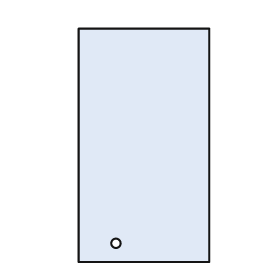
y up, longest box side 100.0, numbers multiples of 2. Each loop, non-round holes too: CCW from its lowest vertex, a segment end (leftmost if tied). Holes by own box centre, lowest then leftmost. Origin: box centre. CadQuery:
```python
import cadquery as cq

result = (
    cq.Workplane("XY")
    .moveTo(-28.0, -50.0)
    .lineTo(28.0, -50.0)
    .lineTo(28.0, 50.0)
    .lineTo(-28.0, 50.0)
    .close()
    .moveTo(-12.0, -42.0)
    .circle(2.0)
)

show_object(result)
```